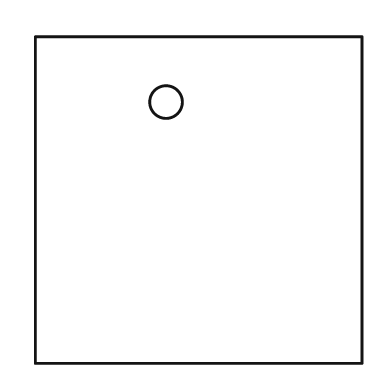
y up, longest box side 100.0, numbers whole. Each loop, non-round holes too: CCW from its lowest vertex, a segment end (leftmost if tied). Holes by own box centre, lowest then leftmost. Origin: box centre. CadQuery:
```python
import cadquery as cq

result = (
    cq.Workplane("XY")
    .moveTo(-50.0, -50.0)
    .lineTo(50.0, -50.0)
    .lineTo(50.0, 50.0)
    .lineTo(-50.0, 50.0)
    .close()
    .moveTo(-10.0, 30.0)
    .circle(5.0)
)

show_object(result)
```